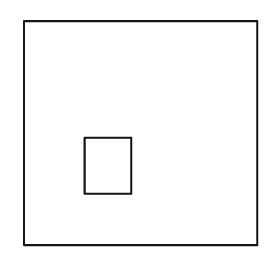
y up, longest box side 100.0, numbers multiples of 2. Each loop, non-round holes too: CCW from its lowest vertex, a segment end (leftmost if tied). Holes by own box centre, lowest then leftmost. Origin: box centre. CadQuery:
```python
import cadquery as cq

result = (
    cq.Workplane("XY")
    .moveTo(-50.0, -48.0)
    .lineTo(50.0, -48.0)
    .lineTo(50.0, 48.0)
    .lineTo(-50.0, 48.0)
    .close()
    .moveTo(-24.0, -26.0)
    .lineTo(-4.0, -26.0)
    .lineTo(-4.0, -2.0)
    .lineTo(-24.0, -2.0)
    .close()
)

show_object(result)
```